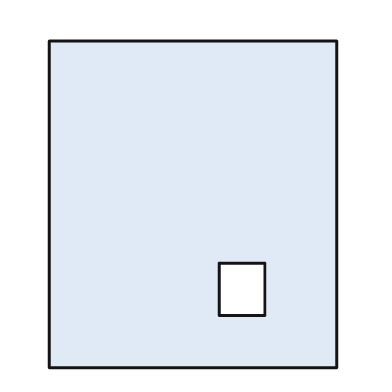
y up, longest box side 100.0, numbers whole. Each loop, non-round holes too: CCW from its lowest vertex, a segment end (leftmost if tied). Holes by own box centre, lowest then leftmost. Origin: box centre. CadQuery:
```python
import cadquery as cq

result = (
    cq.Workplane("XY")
    .moveTo(-44.0, -50.0)
    .lineTo(44.0, -50.0)
    .lineTo(44.0, 50.0)
    .lineTo(-44.0, 50.0)
    .close()
    .moveTo(8.0, -34.0)
    .lineTo(22.0, -34.0)
    .lineTo(22.0, -18.0)
    .lineTo(8.0, -18.0)
    .close()
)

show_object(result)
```